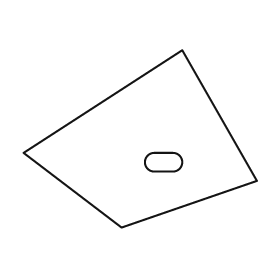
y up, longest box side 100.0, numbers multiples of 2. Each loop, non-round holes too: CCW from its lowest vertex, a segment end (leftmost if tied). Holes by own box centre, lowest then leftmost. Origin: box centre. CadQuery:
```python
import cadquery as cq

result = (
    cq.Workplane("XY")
    .moveTo(-8.0, -38.0)
    .lineTo(50.0, -18.0)
    .lineTo(18.0, 38.0)
    .lineTo(-50.0, -6.0)
    .close()
    .moveTo(6.0, -14.0)
    .lineTo(14.0, -14.0)
    .threePointArc((18.0, -10.0), (14.0, -6.0))
    .lineTo(6.0, -6.0)
    .threePointArc((2.0, -10.0), (6.0, -14.0))
    .close()
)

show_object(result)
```